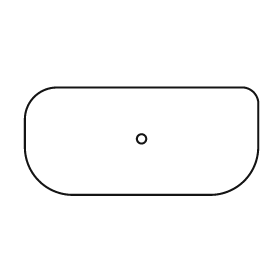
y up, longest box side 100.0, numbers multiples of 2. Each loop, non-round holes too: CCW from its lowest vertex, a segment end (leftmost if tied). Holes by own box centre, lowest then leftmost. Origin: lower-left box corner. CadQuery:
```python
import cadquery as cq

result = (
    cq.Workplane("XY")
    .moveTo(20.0, 0.0)
    .lineTo(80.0, 0.0)
    .threePointArc((94.0, 6.0), (100.0, 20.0))
    .lineTo(100.0, 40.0)
    .threePointArc((98.0, 44.0), (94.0, 46.0))
    .lineTo(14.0, 46.0)
    .threePointArc((4.0, 42.0), (0.0, 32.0))
    .lineTo(0.0, 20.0)
    .threePointArc((6.0, 6.0), (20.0, 0.0))
    .close()
    .moveTo(50.0, 24.0)
    .circle(2.0)
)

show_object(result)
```